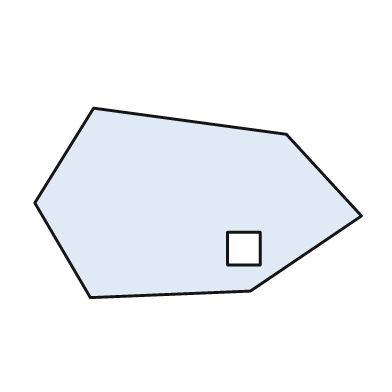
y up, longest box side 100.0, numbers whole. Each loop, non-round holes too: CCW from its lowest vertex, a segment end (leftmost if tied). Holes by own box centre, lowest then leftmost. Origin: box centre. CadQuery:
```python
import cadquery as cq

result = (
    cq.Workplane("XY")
    .moveTo(-33.0, -29.0)
    .lineTo(16.0, -27.0)
    .lineTo(50.0, -4.0)
    .lineTo(27.0, 21.0)
    .lineTo(-32.0, 29.0)
    .lineTo(-50.0, 0.0)
    .close()
    .moveTo(9.0, -19.0)
    .lineTo(19.0, -19.0)
    .lineTo(19.0, -9.0)
    .lineTo(9.0, -9.0)
    .close()
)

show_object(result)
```